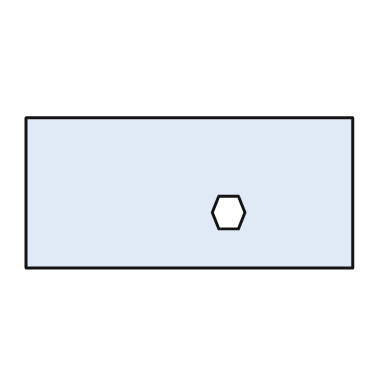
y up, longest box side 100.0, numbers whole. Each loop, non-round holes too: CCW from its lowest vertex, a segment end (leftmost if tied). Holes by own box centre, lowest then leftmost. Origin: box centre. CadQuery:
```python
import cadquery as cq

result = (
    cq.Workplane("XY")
    .moveTo(-50.0, -23.0)
    .lineTo(50.0, -23.0)
    .lineTo(50.0, 23.0)
    .lineTo(-50.0, 23.0)
    .close()
    .moveTo(9.0, -11.0)
    .lineTo(15.0, -11.0)
    .lineTo(17.0, -6.0)
    .lineTo(15.0, -1.0)
    .lineTo(9.0, -1.0)
    .lineTo(7.0, -6.0)
    .close()
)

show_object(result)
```